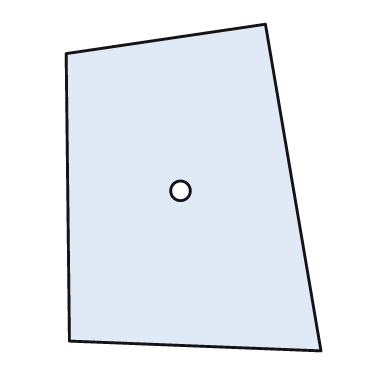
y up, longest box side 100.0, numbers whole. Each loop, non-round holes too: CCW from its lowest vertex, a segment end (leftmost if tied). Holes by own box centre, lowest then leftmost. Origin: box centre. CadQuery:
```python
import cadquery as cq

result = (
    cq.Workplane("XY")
    .moveTo(39.0, -50.0)
    .lineTo(22.0, 50.0)
    .lineTo(-39.0, 41.0)
    .lineTo(-38.0, -47.0)
    .close()
    .moveTo(-4.0, -1.0)
    .circle(3.0)
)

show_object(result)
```